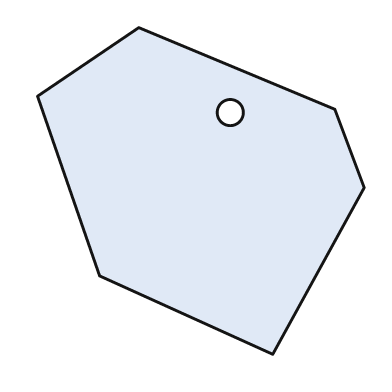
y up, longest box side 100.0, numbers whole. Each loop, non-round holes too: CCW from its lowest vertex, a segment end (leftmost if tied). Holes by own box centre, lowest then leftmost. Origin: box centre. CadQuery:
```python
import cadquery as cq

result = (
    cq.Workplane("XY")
    .moveTo(22.0, -50.0)
    .lineTo(50.0, 1.0)
    .lineTo(41.0, 25.0)
    .lineTo(-19.0, 50.0)
    .lineTo(-50.0, 29.0)
    .lineTo(-31.0, -26.0)
    .close()
    .moveTo(9.0, 24.0)
    .circle(4.0)
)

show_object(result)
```